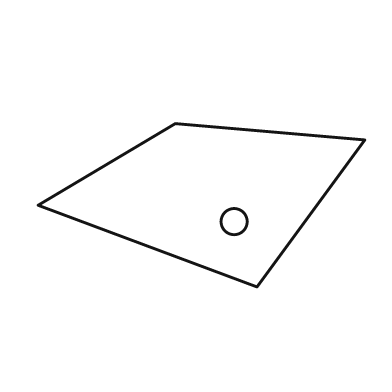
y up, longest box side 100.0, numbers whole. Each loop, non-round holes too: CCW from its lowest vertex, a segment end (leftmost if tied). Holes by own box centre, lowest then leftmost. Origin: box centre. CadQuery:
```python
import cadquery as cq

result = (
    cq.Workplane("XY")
    .moveTo(17.0, -25.0)
    .lineTo(50.0, 20.0)
    .lineTo(-8.0, 25.0)
    .lineTo(-50.0, 0.0)
    .close()
    .moveTo(10.0, -5.0)
    .circle(4.0)
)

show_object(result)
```